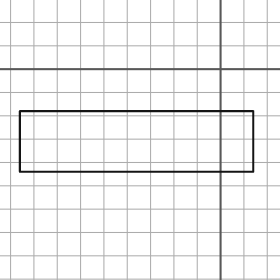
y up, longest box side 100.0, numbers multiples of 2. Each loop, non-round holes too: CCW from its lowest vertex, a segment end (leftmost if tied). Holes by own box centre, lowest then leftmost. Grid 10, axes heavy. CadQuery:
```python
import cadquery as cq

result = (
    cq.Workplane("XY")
    .moveTo(-86.0, -44.0)
    .lineTo(14.0, -44.0)
    .lineTo(14.0, -18.0)
    .lineTo(-86.0, -18.0)
    .close()
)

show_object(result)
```